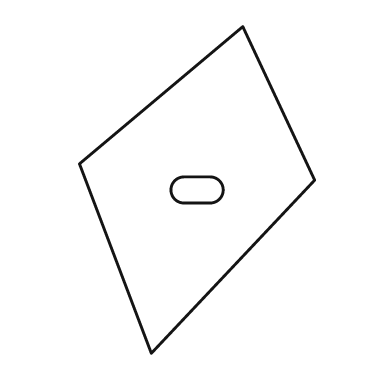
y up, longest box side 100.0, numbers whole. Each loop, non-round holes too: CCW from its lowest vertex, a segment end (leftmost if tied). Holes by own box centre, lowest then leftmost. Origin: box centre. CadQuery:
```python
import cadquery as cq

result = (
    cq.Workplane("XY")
    .moveTo(-14.0, -50.0)
    .lineTo(36.0, 3.0)
    .lineTo(14.0, 50.0)
    .lineTo(-36.0, 8.0)
    .close()
    .moveTo(-4.0, -4.0)
    .lineTo(4.0, -4.0)
    .threePointArc((8.0, 0.0), (4.0, 4.0))
    .lineTo(-4.0, 4.0)
    .threePointArc((-8.0, 0.0), (-4.0, -4.0))
    .close()
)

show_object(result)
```